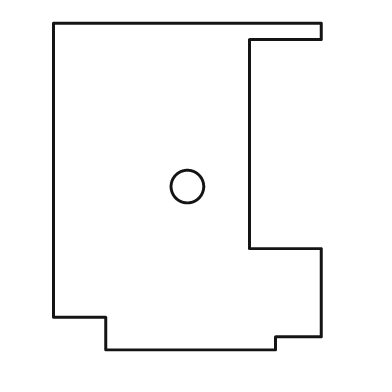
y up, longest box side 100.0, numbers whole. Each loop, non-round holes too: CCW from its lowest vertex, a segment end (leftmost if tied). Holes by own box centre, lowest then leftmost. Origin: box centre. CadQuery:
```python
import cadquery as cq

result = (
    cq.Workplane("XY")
    .moveTo(-25.0, -50.0)
    .lineTo(27.0, -50.0)
    .lineTo(27.0, -46.0)
    .lineTo(41.0, -46.0)
    .lineTo(41.0, -19.0)
    .lineTo(19.0, -19.0)
    .lineTo(19.0, 45.0)
    .lineTo(41.0, 45.0)
    .lineTo(41.0, 50.0)
    .lineTo(-41.0, 50.0)
    .lineTo(-41.0, -40.0)
    .lineTo(-25.0, -40.0)
    .close()
    .moveTo(0.0, 0.0)
    .circle(5.0)
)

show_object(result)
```